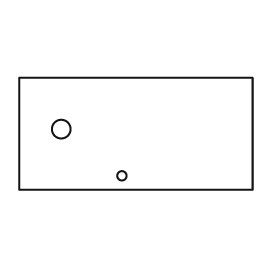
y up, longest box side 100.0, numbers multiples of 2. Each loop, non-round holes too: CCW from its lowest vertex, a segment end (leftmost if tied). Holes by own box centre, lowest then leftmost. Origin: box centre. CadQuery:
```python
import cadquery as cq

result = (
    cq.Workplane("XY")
    .moveTo(-50.0, -24.0)
    .lineTo(50.0, -24.0)
    .lineTo(50.0, 24.0)
    .lineTo(-50.0, 24.0)
    .close()
    .moveTo(-6.0, -18.0)
    .circle(2.0)
    .moveTo(-32.0, 2.0)
    .circle(4.0)
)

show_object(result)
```